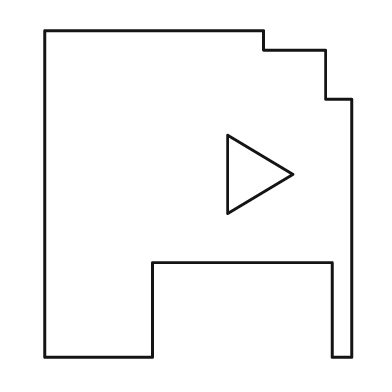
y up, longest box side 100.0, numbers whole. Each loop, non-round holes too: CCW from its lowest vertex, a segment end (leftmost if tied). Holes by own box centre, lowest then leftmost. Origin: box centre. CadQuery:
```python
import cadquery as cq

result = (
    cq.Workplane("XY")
    .moveTo(-47.0, -50.0)
    .lineTo(-14.0, -50.0)
    .lineTo(-14.0, -21.0)
    .lineTo(41.0, -21.0)
    .lineTo(41.0, -50.0)
    .lineTo(47.0, -50.0)
    .lineTo(47.0, 29.0)
    .lineTo(39.0, 29.0)
    .lineTo(39.0, 44.0)
    .lineTo(20.0, 44.0)
    .lineTo(20.0, 50.0)
    .lineTo(-47.0, 50.0)
    .close()
    .moveTo(9.0, -6.0)
    .lineTo(29.0, 6.0)
    .lineTo(9.0, 18.0)
    .close()
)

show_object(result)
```